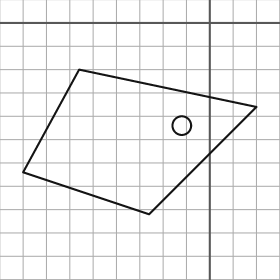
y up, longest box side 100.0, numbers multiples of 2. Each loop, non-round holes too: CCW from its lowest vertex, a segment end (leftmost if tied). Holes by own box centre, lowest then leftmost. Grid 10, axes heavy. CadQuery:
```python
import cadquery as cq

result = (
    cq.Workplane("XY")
    .moveTo(-26.0, -82.0)
    .lineTo(20.0, -36.0)
    .lineTo(-56.0, -20.0)
    .lineTo(-80.0, -64.0)
    .close()
    .moveTo(-12.0, -44.0)
    .circle(4.0)
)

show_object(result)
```